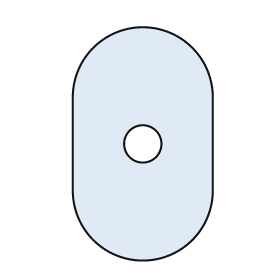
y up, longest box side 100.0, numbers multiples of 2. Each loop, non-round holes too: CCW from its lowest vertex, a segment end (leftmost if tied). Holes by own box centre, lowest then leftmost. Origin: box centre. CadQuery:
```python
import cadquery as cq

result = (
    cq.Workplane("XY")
    .moveTo(-30.0, -20.0)
    .threePointArc((0.0, -50.0), (30.0, -20.0))
    .lineTo(30.0, 20.0)
    .threePointArc((0.0, 50.0), (-30.0, 20.0))
    .close()
    .moveTo(0.0, 0.0)
    .circle(8.0)
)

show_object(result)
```